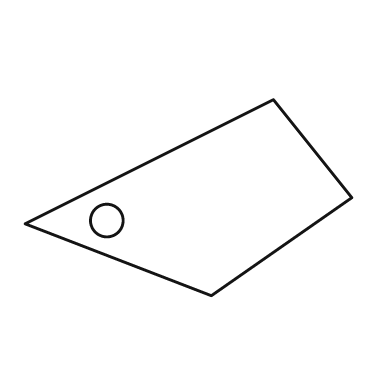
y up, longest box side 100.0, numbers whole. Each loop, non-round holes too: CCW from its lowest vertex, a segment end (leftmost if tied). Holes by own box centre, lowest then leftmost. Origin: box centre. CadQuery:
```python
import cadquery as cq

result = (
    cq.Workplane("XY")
    .moveTo(7.0, -30.0)
    .lineTo(50.0, 0.0)
    .lineTo(26.0, 30.0)
    .lineTo(-50.0, -8.0)
    .close()
    .moveTo(-25.0, -7.0)
    .circle(5.0)
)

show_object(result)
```